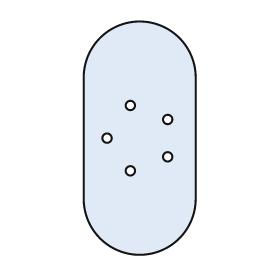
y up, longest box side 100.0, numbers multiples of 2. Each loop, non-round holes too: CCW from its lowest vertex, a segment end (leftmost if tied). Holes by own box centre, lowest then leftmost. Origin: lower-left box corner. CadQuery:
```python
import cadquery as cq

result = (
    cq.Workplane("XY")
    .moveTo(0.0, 24.0)
    .threePointArc((24.0, 0.0), (48.0, 24.0))
    .lineTo(48.0, 76.0)
    .threePointArc((24.0, 100.0), (0.0, 76.0))
    .close()
    .moveTo(20.0, 36.0)
    .circle(2.0)
    .moveTo(36.0, 42.0)
    .circle(2.0)
    .moveTo(10.0, 50.0)
    .circle(2.0)
    .moveTo(36.0, 58.0)
    .circle(2.0)
    .moveTo(20.0, 64.0)
    .circle(2.0)
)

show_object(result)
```